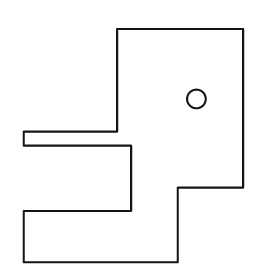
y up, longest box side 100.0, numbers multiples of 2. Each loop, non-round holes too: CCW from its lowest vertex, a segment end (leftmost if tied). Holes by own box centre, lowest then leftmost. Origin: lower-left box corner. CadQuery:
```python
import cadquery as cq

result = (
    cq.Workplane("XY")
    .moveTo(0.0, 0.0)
    .lineTo(66.0, 0.0)
    .lineTo(66.0, 32.0)
    .lineTo(94.0, 32.0)
    .lineTo(94.0, 100.0)
    .lineTo(40.0, 100.0)
    .lineTo(40.0, 56.0)
    .lineTo(0.0, 56.0)
    .lineTo(0.0, 50.0)
    .lineTo(46.0, 50.0)
    .lineTo(46.0, 22.0)
    .lineTo(0.0, 22.0)
    .close()
    .moveTo(74.0, 70.0)
    .circle(4.0)
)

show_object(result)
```